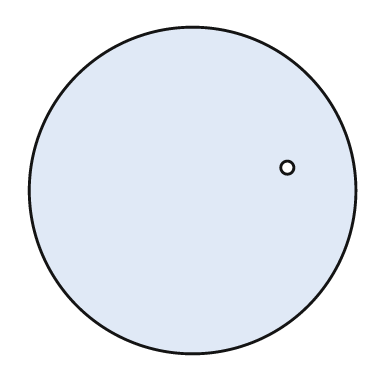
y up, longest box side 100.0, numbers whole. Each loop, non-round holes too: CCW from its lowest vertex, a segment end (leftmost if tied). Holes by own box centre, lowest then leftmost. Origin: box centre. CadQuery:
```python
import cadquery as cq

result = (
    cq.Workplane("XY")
    .moveTo(0.0, 0.0)
    .circle(50.0)
    .moveTo(29.0, 7.0)
    .circle(2.0)
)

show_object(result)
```